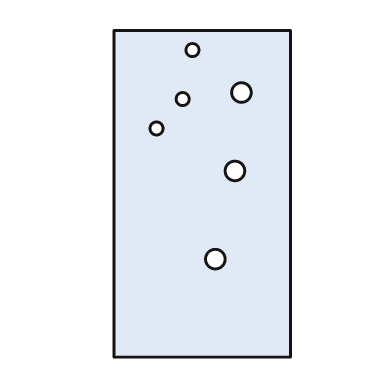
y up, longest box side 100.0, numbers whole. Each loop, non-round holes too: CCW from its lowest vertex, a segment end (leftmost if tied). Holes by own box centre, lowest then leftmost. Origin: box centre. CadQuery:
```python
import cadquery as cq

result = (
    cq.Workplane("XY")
    .moveTo(-27.0, -50.0)
    .lineTo(27.0, -50.0)
    .lineTo(27.0, 50.0)
    .lineTo(-27.0, 50.0)
    .close()
    .moveTo(4.0, -20.0)
    .circle(3.0)
    .moveTo(10.0, 7.0)
    .circle(3.0)
    .moveTo(-14.0, 20.0)
    .circle(2.0)
    .moveTo(-6.0, 29.0)
    .circle(2.0)
    .moveTo(12.0, 31.0)
    .circle(3.0)
    .moveTo(-3.0, 44.0)
    .circle(2.0)
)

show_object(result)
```